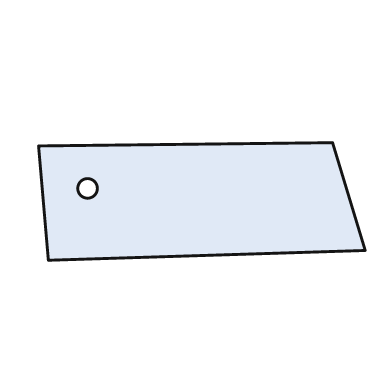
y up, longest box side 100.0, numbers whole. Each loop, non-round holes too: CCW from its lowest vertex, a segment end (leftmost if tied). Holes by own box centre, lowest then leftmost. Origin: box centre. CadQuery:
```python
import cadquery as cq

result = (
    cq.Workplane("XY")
    .moveTo(-47.0, -18.0)
    .lineTo(50.0, -15.0)
    .lineTo(40.0, 18.0)
    .lineTo(-50.0, 17.0)
    .close()
    .moveTo(-35.0, 4.0)
    .circle(3.0)
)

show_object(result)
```